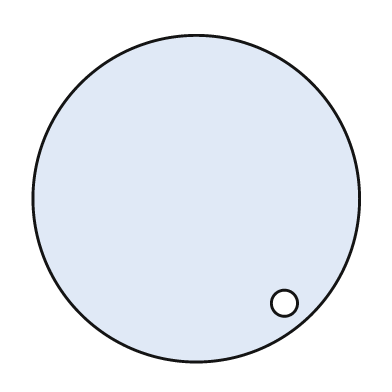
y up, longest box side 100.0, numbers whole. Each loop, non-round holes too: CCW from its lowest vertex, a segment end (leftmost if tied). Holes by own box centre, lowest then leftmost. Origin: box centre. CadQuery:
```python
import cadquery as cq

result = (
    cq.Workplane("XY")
    .moveTo(0.0, 0.0)
    .circle(50.0)
    .moveTo(27.0, -32.0)
    .circle(4.0)
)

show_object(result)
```